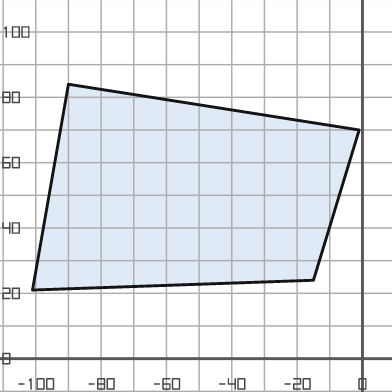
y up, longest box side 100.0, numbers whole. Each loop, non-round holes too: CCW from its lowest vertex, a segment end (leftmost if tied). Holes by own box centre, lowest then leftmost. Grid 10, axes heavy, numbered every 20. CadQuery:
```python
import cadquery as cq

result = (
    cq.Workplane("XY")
    .moveTo(-101.0, 21.0)
    .lineTo(-15.0, 24.0)
    .lineTo(-1.0, 70.0)
    .lineTo(-90.0, 84.0)
    .close()
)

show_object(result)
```